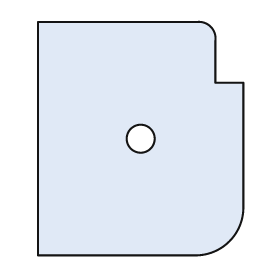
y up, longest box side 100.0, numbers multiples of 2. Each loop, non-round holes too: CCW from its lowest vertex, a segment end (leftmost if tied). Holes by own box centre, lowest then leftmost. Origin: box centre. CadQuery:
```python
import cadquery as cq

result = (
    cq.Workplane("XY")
    .moveTo(-44.0, -50.0)
    .lineTo(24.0, -50.0)
    .threePointArc((38.0, -44.0), (44.0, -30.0))
    .lineTo(44.0, 24.0)
    .lineTo(32.0, 24.0)
    .lineTo(32.0, 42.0)
    .threePointArc((30.0, 48.0), (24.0, 50.0))
    .lineTo(-44.0, 50.0)
    .close()
    .moveTo(0.0, 0.0)
    .circle(6.0)
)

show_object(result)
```